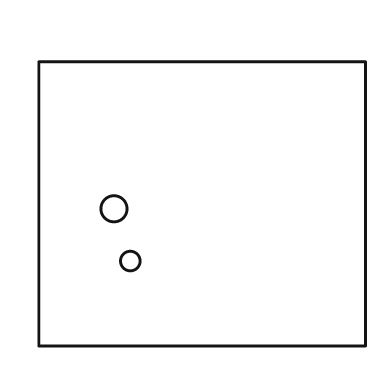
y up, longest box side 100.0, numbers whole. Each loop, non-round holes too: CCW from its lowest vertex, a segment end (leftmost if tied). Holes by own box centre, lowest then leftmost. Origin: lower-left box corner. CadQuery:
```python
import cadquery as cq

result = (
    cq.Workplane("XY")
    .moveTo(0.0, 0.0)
    .lineTo(100.0, 0.0)
    .lineTo(100.0, 87.0)
    .lineTo(0.0, 87.0)
    .close()
    .moveTo(28.0, 26.0)
    .circle(3.0)
    .moveTo(23.0, 42.0)
    .circle(4.0)
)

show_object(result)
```